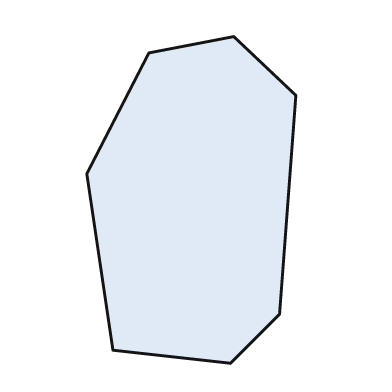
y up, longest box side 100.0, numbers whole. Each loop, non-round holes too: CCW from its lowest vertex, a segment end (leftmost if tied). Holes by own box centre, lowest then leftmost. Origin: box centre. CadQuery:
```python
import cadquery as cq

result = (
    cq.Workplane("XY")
    .moveTo(12.0, -50.0)
    .lineTo(27.0, -35.0)
    .lineTo(32.0, 32.0)
    .lineTo(13.0, 50.0)
    .lineTo(-13.0, 45.0)
    .lineTo(-32.0, 8.0)
    .lineTo(-24.0, -46.0)
    .close()
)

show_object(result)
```